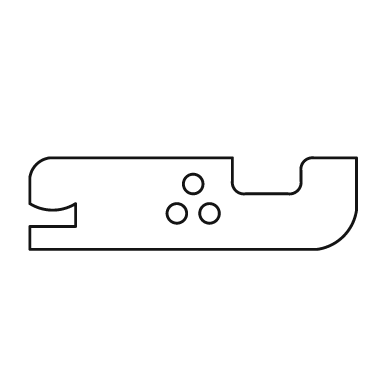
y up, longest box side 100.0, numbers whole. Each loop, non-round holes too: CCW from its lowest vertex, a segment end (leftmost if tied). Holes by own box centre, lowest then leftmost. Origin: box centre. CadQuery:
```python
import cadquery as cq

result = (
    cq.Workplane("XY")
    .moveTo(-50.0, -14.0)
    .lineTo(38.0, -14.0)
    .threePointArc((46.0, -10.0), (50.0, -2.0))
    .lineTo(50.0, 14.0)
    .lineTo(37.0, 14.0)
    .threePointArc((34.0, 13.0), (33.0, 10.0))
    .lineTo(33.0, 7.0)
    .threePointArc((32.0, 4.0), (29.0, 3.0))
    .lineTo(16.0, 3.0)
    .threePointArc((13.0, 4.0), (12.0, 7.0))
    .lineTo(12.0, 14.0)
    .lineTo(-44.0, 14.0)
    .threePointArc((-48.0, 12.0), (-50.0, 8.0))
    .lineTo(-50.0, 0.0)
    .threePointArc((-43.0, -2.0), (-36.0, 0.0))
    .lineTo(-36.0, -7.0)
    .lineTo(-50.0, -7.0)
    .close()
    .moveTo(-5.0, -3.0)
    .circle(3.0)
    .moveTo(5.0, -3.0)
    .circle(3.0)
    .moveTo(0.0, 6.0)
    .circle(3.0)
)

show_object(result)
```